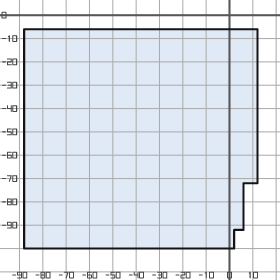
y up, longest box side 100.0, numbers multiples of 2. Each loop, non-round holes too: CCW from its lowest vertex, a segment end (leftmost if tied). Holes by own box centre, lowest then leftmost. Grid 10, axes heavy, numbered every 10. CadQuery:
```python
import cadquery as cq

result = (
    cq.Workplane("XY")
    .moveTo(-88.0, -100.0)
    .lineTo(2.0, -100.0)
    .lineTo(2.0, -92.0)
    .lineTo(6.0, -92.0)
    .lineTo(6.0, -72.0)
    .lineTo(12.0, -72.0)
    .lineTo(12.0, -6.0)
    .lineTo(-88.0, -6.0)
    .close()
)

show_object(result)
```